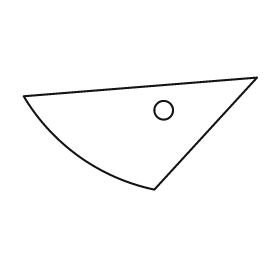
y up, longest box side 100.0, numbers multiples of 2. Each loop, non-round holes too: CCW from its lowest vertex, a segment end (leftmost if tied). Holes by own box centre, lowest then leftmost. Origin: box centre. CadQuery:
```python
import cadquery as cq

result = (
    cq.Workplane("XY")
    .moveTo(6.0, -24.0)
    .lineTo(50.0, 24.0)
    .lineTo(-50.0, 16.0)
    .threePointArc((-26.0, -10.0), (6.0, -24.0))
    .close()
    .moveTo(10.0, 10.0)
    .circle(4.0)
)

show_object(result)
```